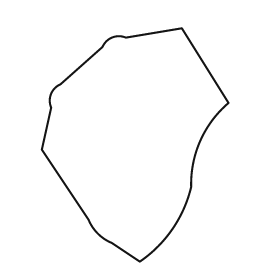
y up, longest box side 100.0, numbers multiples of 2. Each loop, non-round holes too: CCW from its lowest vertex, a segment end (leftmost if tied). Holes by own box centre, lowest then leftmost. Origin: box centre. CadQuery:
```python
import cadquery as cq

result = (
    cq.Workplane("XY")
    .moveTo(2.0, -50.0)
    .threePointArc((16.0, -36.0), (24.0, -18.0))
    .threePointArc((28.0, 2.0), (40.0, 18.0))
    .lineTo(20.0, 50.0)
    .lineTo(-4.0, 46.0)
    .threePointArc((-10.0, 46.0), (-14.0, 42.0))
    .lineTo(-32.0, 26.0)
    .threePointArc((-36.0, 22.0), (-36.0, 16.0))
    .lineTo(-40.0, -2.0)
    .lineTo(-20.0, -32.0)
    .threePointArc((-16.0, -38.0), (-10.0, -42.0))
    .close()
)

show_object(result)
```